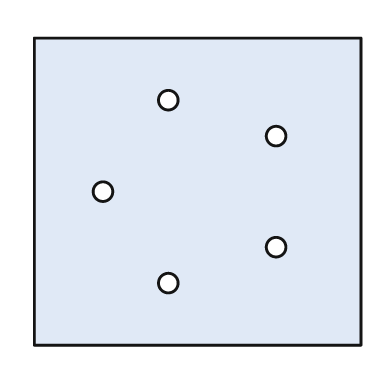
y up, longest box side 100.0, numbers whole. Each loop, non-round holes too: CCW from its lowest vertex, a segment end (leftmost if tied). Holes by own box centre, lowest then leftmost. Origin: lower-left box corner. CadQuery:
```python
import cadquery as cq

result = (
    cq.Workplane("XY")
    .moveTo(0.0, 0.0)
    .lineTo(100.0, 0.0)
    .lineTo(100.0, 94.0)
    .lineTo(0.0, 94.0)
    .close()
    .moveTo(41.0, 19.0)
    .circle(3.0)
    .moveTo(74.0, 30.0)
    .circle(3.0)
    .moveTo(21.0, 47.0)
    .circle(3.0)
    .moveTo(74.0, 64.0)
    .circle(3.0)
    .moveTo(41.0, 75.0)
    .circle(3.0)
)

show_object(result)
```